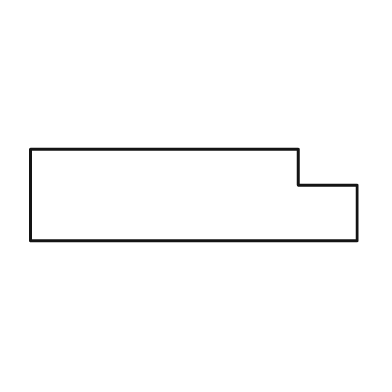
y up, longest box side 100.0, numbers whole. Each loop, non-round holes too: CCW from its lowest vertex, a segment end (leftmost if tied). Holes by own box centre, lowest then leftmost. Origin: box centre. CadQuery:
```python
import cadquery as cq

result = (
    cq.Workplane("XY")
    .moveTo(-50.0, -14.0)
    .lineTo(50.0, -14.0)
    .lineTo(50.0, 3.0)
    .lineTo(32.0, 3.0)
    .lineTo(32.0, 14.0)
    .lineTo(-50.0, 14.0)
    .close()
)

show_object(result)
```